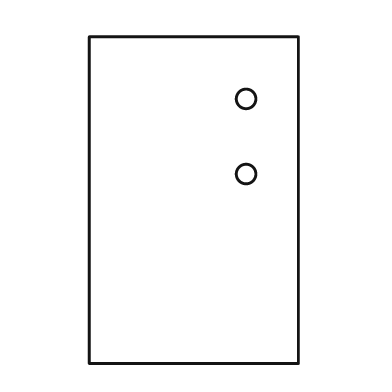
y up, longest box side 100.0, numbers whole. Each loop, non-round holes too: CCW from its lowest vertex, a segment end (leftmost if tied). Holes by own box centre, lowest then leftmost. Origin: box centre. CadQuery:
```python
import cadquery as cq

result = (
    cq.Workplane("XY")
    .moveTo(-32.0, -50.0)
    .lineTo(32.0, -50.0)
    .lineTo(32.0, 50.0)
    .lineTo(-32.0, 50.0)
    .close()
    .moveTo(16.0, 8.0)
    .circle(3.0)
    .moveTo(16.0, 31.0)
    .circle(3.0)
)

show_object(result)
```